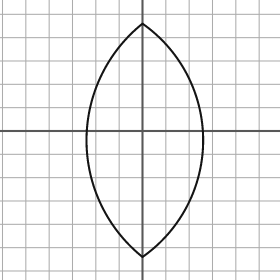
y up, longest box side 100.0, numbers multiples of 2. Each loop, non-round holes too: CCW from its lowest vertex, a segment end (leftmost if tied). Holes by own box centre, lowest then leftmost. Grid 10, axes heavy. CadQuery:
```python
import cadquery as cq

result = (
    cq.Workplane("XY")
    .moveTo(0.0, -54.0)
    .threePointArc((26.0, -4.0), (0.0, 46.0))
    .threePointArc((-24.0, -4.0), (0.0, -54.0))
    .close()
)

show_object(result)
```